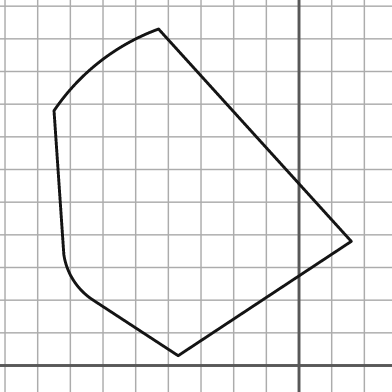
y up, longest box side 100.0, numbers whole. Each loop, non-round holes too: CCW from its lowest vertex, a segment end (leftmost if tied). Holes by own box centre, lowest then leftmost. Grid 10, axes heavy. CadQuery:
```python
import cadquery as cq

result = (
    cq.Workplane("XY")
    .moveTo(-37.0, 3.0)
    .lineTo(16.0, 38.0)
    .lineTo(-43.0, 103.0)
    .threePointArc((-61.0, 93.0), (-75.0, 78.0))
    .lineTo(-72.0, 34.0)
    .threePointArc((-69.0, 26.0), (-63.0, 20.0))
    .close()
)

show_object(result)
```